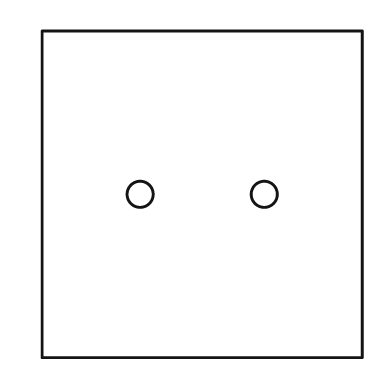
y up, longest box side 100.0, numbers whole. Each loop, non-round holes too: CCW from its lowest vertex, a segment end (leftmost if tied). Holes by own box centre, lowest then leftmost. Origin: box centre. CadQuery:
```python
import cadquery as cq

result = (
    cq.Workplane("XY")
    .moveTo(-49.0, -50.0)
    .lineTo(49.0, -50.0)
    .lineTo(49.0, 50.0)
    .lineTo(-49.0, 50.0)
    .close()
    .moveTo(-19.0, 0.0)
    .circle(4.0)
    .moveTo(19.0, 0.0)
    .circle(4.0)
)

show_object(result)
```